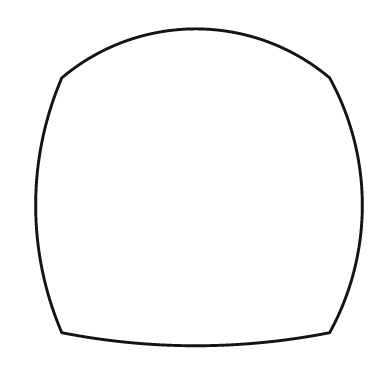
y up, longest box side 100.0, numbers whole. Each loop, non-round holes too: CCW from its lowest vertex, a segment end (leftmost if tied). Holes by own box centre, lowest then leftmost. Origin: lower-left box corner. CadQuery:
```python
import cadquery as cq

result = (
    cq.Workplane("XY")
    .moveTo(8.0, 4.0)
    .threePointArc((49.0, 0.0), (90.0, 4.0))
    .threePointArc((100.0, 43.0), (90.0, 82.0))
    .threePointArc((49.0, 97.0), (8.0, 82.0))
    .threePointArc((0.0, 43.0), (8.0, 4.0))
    .close()
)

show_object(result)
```